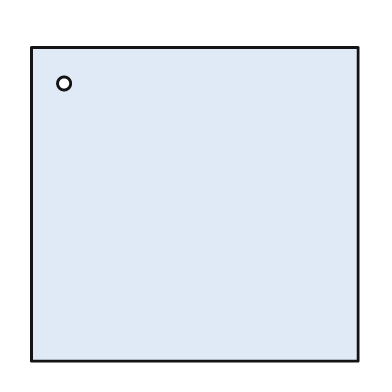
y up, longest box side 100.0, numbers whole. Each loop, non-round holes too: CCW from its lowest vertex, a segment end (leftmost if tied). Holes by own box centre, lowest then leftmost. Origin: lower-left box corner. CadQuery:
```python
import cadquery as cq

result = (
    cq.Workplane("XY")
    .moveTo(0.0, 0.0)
    .lineTo(100.0, 0.0)
    .lineTo(100.0, 96.0)
    .lineTo(0.0, 96.0)
    .close()
    .moveTo(10.0, 85.0)
    .circle(2.0)
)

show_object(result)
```